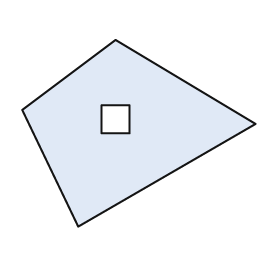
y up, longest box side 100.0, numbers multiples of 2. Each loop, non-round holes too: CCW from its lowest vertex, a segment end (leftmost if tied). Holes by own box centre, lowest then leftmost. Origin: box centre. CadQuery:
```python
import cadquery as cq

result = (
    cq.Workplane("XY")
    .moveTo(-26.0, -40.0)
    .lineTo(50.0, 4.0)
    .lineTo(-10.0, 40.0)
    .lineTo(-50.0, 10.0)
    .close()
    .moveTo(-16.0, 0.0)
    .lineTo(-4.0, 0.0)
    .lineTo(-4.0, 12.0)
    .lineTo(-16.0, 12.0)
    .close()
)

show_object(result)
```